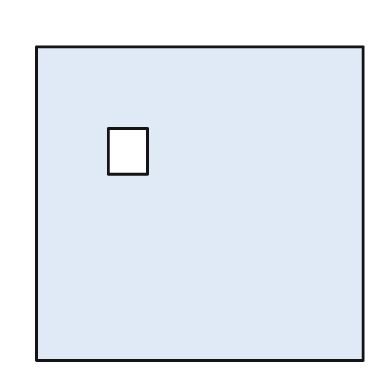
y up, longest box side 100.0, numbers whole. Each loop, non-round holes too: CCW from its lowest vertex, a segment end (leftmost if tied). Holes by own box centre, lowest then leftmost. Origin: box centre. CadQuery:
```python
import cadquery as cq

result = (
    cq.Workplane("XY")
    .moveTo(-50.0, -48.0)
    .lineTo(50.0, -48.0)
    .lineTo(50.0, 48.0)
    .lineTo(-50.0, 48.0)
    .close()
    .moveTo(-28.0, 9.0)
    .lineTo(-16.0, 9.0)
    .lineTo(-16.0, 23.0)
    .lineTo(-28.0, 23.0)
    .close()
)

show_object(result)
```